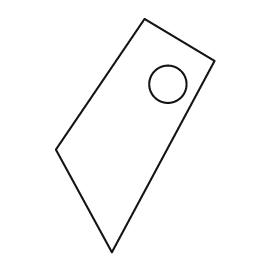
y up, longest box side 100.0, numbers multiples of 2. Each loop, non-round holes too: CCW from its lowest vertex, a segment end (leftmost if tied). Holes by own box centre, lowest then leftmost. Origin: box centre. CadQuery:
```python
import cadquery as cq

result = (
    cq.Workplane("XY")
    .moveTo(-10.0, -50.0)
    .lineTo(34.0, 32.0)
    .lineTo(4.0, 50.0)
    .lineTo(-34.0, -6.0)
    .close()
    .moveTo(14.0, 22.0)
    .circle(8.0)
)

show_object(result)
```